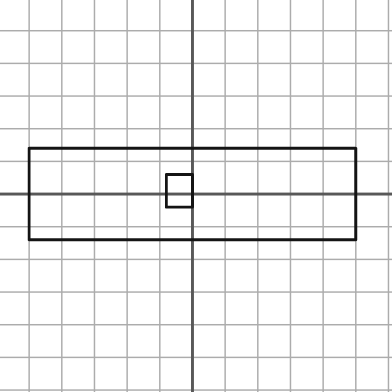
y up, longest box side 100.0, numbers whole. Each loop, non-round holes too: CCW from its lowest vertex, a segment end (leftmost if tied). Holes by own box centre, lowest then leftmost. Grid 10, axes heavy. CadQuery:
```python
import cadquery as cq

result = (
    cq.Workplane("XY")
    .moveTo(-50.0, -14.0)
    .lineTo(50.0, -14.0)
    .lineTo(50.0, 14.0)
    .lineTo(-50.0, 14.0)
    .close()
    .moveTo(-8.0, -4.0)
    .lineTo(0.0, -4.0)
    .lineTo(0.0, 6.0)
    .lineTo(-8.0, 6.0)
    .close()
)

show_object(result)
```